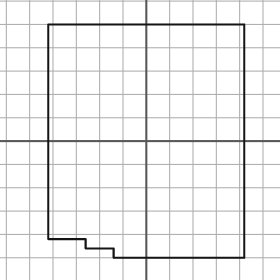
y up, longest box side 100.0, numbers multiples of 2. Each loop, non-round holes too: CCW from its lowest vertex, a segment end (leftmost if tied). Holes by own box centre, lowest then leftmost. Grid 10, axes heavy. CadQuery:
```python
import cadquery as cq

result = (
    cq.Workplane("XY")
    .moveTo(-14.0, -50.0)
    .lineTo(42.0, -50.0)
    .lineTo(42.0, 50.0)
    .lineTo(-42.0, 50.0)
    .lineTo(-42.0, -42.0)
    .lineTo(-26.0, -42.0)
    .lineTo(-26.0, -46.0)
    .lineTo(-14.0, -46.0)
    .close()
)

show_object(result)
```